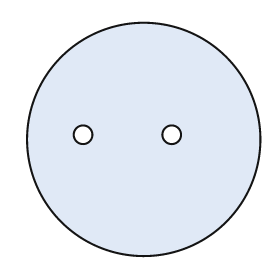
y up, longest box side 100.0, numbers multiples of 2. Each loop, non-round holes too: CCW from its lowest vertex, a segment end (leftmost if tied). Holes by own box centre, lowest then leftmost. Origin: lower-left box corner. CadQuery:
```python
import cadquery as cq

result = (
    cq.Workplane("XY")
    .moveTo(50.0, 50.0)
    .circle(50.0)
    .moveTo(24.0, 52.0)
    .circle(4.0)
    .moveTo(62.0, 52.0)
    .circle(4.0)
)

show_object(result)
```